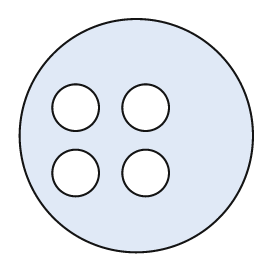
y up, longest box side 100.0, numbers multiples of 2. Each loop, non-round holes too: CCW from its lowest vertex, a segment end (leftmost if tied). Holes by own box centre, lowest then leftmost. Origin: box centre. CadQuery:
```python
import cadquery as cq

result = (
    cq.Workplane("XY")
    .moveTo(0.0, 0.0)
    .circle(50.0)
    .moveTo(-26.0, -16.0)
    .circle(10.0)
    .moveTo(4.0, -16.0)
    .circle(10.0)
    .moveTo(-26.0, 12.0)
    .circle(10.0)
    .moveTo(4.0, 12.0)
    .circle(10.0)
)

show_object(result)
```